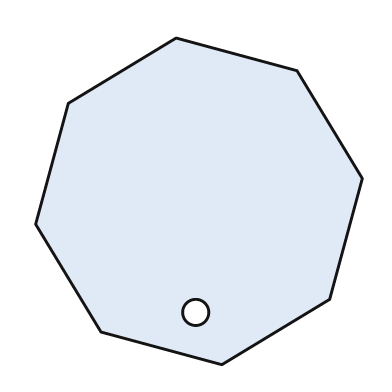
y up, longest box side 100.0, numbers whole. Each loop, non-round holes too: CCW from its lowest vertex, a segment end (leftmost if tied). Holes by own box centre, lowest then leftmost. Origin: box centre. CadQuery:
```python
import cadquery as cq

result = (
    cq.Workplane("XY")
    .moveTo(7.0, -50.0)
    .lineTo(40.0, -30.0)
    .lineTo(50.0, 7.0)
    .lineTo(30.0, 40.0)
    .lineTo(-7.0, 50.0)
    .lineTo(-40.0, 30.0)
    .lineTo(-50.0, -7.0)
    .lineTo(-30.0, -40.0)
    .close()
    .moveTo(-1.0, -34.0)
    .circle(4.0)
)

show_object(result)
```